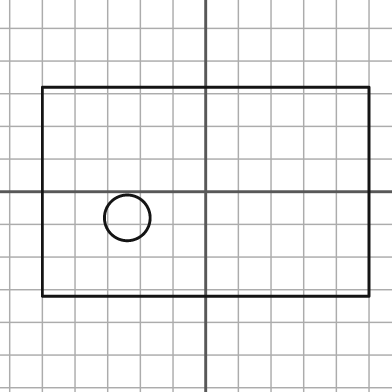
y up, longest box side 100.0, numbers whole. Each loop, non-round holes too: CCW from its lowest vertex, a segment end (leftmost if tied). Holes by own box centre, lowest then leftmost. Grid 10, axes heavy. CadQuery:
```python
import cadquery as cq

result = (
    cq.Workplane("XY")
    .moveTo(-50.0, -32.0)
    .lineTo(50.0, -32.0)
    .lineTo(50.0, 32.0)
    .lineTo(-50.0, 32.0)
    .close()
    .moveTo(-24.0, -8.0)
    .circle(7.0)
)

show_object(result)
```